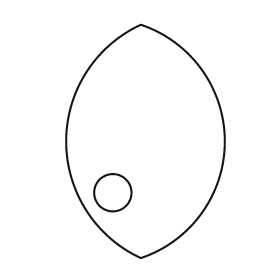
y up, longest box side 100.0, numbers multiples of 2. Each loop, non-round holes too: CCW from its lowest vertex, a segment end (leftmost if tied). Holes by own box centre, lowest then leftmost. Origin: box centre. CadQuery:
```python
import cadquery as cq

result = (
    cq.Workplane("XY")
    .moveTo(-2.0, -50.0)
    .threePointArc((34.0, 0.0), (-2.0, 50.0))
    .threePointArc((-34.0, 0.0), (-2.0, -50.0))
    .close()
    .moveTo(-14.0, -22.0)
    .circle(8.0)
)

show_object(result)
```